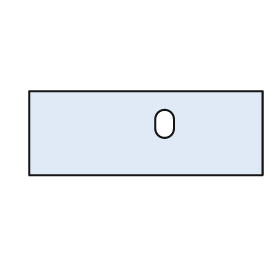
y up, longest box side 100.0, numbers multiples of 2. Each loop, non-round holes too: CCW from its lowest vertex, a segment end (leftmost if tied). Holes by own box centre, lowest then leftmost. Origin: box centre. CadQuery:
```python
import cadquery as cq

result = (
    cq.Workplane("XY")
    .moveTo(-50.0, -18.0)
    .lineTo(50.0, -18.0)
    .lineTo(50.0, 18.0)
    .lineTo(-50.0, 18.0)
    .close()
    .moveTo(4.0, 2.0)
    .threePointArc((8.0, -2.0), (12.0, 2.0))
    .lineTo(12.0, 6.0)
    .threePointArc((8.0, 10.0), (4.0, 6.0))
    .close()
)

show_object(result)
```